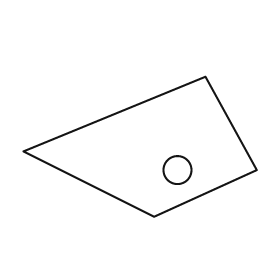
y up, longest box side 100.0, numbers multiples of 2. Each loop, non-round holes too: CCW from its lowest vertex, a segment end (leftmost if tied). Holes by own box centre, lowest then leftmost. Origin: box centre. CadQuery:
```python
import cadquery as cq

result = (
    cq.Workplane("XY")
    .moveTo(6.0, -30.0)
    .lineTo(50.0, -10.0)
    .lineTo(28.0, 30.0)
    .lineTo(-50.0, -2.0)
    .close()
    .moveTo(16.0, -10.0)
    .circle(6.0)
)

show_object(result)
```